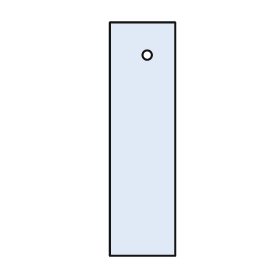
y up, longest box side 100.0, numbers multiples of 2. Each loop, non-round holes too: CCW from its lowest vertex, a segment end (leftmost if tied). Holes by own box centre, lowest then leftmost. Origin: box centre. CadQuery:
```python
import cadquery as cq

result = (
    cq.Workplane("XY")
    .moveTo(-14.0, -50.0)
    .lineTo(14.0, -50.0)
    .lineTo(14.0, 50.0)
    .lineTo(-14.0, 50.0)
    .close()
    .moveTo(2.0, 36.0)
    .circle(2.0)
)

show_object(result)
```